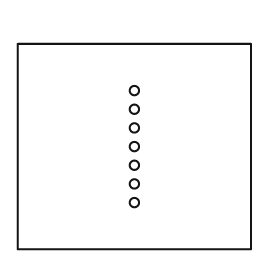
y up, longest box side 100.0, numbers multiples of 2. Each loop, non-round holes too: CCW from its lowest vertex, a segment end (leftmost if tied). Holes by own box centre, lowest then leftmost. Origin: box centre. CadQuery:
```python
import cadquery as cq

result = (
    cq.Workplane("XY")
    .moveTo(-50.0, -44.0)
    .lineTo(50.0, -44.0)
    .lineTo(50.0, 44.0)
    .lineTo(-50.0, 44.0)
    .close()
    .moveTo(0.0, -24.0)
    .circle(2.0)
    .moveTo(0.0, -16.0)
    .circle(2.0)
    .moveTo(0.0, -8.0)
    .circle(2.0)
    .moveTo(0.0, 0.0)
    .circle(2.0)
    .moveTo(0.0, 8.0)
    .circle(2.0)
    .moveTo(0.0, 16.0)
    .circle(2.0)
    .moveTo(0.0, 24.0)
    .circle(2.0)
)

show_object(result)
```